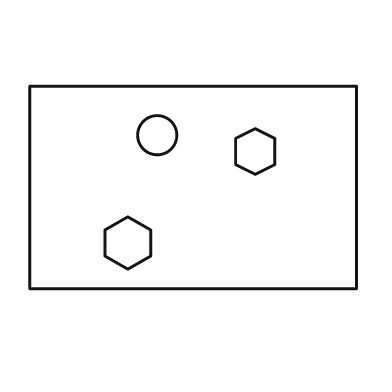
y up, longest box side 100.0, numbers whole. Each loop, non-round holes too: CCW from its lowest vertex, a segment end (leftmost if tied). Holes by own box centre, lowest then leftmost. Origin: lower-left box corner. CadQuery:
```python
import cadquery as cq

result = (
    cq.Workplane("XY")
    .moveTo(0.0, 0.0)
    .lineTo(100.0, 0.0)
    .lineTo(100.0, 62.0)
    .lineTo(0.0, 62.0)
    .close()
    .moveTo(30.0, 6.0)
    .lineTo(37.0, 10.0)
    .lineTo(37.0, 18.0)
    .lineTo(30.0, 22.0)
    .lineTo(23.0, 18.0)
    .lineTo(23.0, 10.0)
    .close()
    .moveTo(69.0, 35.0)
    .lineTo(75.0, 38.0)
    .lineTo(75.0, 46.0)
    .lineTo(69.0, 49.0)
    .lineTo(63.0, 46.0)
    .lineTo(63.0, 38.0)
    .close()
    .moveTo(39.0, 47.0)
    .circle(6.0)
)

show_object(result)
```